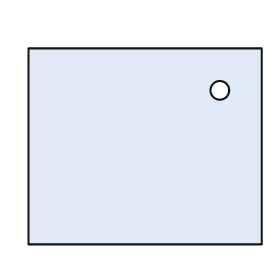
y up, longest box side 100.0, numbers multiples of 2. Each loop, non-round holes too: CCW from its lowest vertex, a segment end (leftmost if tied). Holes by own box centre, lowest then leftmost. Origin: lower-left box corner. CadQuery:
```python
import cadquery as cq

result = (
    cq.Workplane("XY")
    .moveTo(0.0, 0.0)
    .lineTo(100.0, 0.0)
    .lineTo(100.0, 84.0)
    .lineTo(0.0, 84.0)
    .close()
    .moveTo(82.0, 66.0)
    .circle(4.0)
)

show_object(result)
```